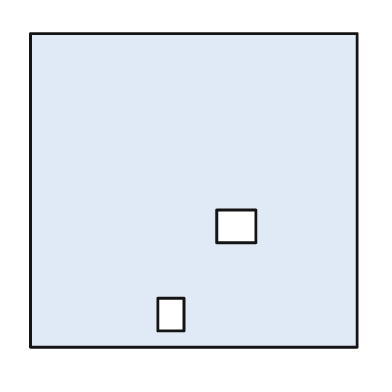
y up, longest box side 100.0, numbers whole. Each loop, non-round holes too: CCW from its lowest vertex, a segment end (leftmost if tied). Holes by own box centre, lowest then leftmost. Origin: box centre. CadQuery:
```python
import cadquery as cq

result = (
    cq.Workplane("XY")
    .moveTo(-50.0, -48.0)
    .lineTo(50.0, -48.0)
    .lineTo(50.0, 48.0)
    .lineTo(-50.0, 48.0)
    .close()
    .moveTo(-11.0, -43.0)
    .lineTo(-3.0, -43.0)
    .lineTo(-3.0, -33.0)
    .lineTo(-11.0, -33.0)
    .close()
    .moveTo(7.0, -16.0)
    .lineTo(19.0, -16.0)
    .lineTo(19.0, -6.0)
    .lineTo(7.0, -6.0)
    .close()
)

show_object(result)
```